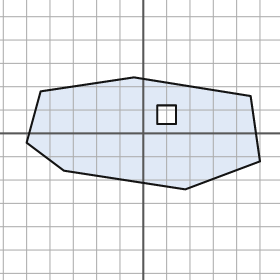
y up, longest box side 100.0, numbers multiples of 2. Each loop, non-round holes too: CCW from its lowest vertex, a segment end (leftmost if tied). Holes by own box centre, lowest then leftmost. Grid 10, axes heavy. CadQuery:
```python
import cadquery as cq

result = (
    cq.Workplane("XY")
    .moveTo(18.0, -24.0)
    .lineTo(50.0, -12.0)
    .lineTo(46.0, 16.0)
    .lineTo(-4.0, 24.0)
    .lineTo(-44.0, 18.0)
    .lineTo(-50.0, -4.0)
    .lineTo(-34.0, -16.0)
    .close()
    .moveTo(6.0, 4.0)
    .lineTo(14.0, 4.0)
    .lineTo(14.0, 12.0)
    .lineTo(6.0, 12.0)
    .close()
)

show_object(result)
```